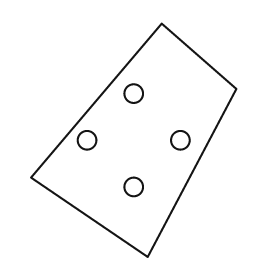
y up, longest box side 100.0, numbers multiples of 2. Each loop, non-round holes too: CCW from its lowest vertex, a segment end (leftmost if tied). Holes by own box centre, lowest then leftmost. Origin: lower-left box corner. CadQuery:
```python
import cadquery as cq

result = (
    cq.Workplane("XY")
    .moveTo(50.0, 0.0)
    .lineTo(88.0, 72.0)
    .lineTo(56.0, 100.0)
    .lineTo(0.0, 34.0)
    .close()
    .moveTo(44.0, 30.0)
    .circle(4.0)
    .moveTo(24.0, 50.0)
    .circle(4.0)
    .moveTo(64.0, 50.0)
    .circle(4.0)
    .moveTo(44.0, 70.0)
    .circle(4.0)
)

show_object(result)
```